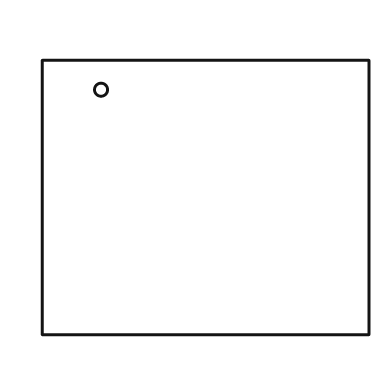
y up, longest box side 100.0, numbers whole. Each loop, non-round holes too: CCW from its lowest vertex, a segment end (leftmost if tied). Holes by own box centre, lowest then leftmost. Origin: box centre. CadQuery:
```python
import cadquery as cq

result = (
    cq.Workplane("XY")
    .moveTo(-50.0, -42.0)
    .lineTo(50.0, -42.0)
    .lineTo(50.0, 42.0)
    .lineTo(-50.0, 42.0)
    .close()
    .moveTo(-32.0, 33.0)
    .circle(2.0)
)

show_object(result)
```